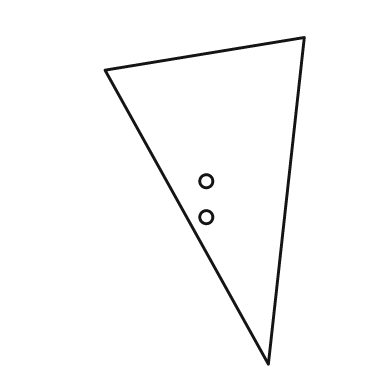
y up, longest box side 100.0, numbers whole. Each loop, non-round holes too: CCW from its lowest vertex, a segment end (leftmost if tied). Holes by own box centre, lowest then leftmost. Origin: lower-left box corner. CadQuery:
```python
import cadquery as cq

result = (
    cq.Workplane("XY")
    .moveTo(50.0, 0.0)
    .lineTo(61.0, 100.0)
    .lineTo(0.0, 90.0)
    .close()
    .moveTo(31.0, 45.0)
    .circle(2.0)
    .moveTo(31.0, 56.0)
    .circle(2.0)
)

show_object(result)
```